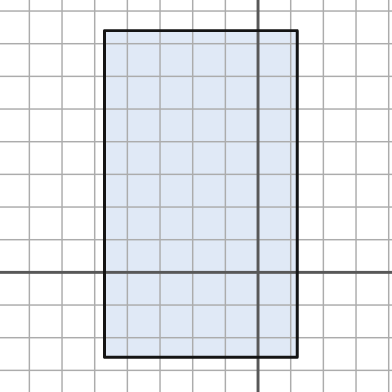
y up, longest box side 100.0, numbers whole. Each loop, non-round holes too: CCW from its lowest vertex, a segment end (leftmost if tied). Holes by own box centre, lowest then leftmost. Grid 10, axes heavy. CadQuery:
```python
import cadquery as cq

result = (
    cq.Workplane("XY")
    .moveTo(-47.0, -26.0)
    .lineTo(12.0, -26.0)
    .lineTo(12.0, 74.0)
    .lineTo(-47.0, 74.0)
    .close()
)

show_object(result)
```